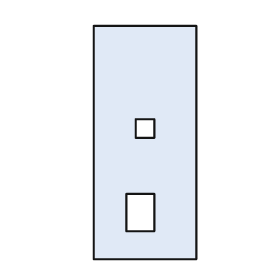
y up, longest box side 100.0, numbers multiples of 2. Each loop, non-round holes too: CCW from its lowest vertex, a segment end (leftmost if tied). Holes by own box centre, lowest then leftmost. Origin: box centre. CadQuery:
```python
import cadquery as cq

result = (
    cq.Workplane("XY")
    .moveTo(-22.0, -50.0)
    .lineTo(22.0, -50.0)
    .lineTo(22.0, 50.0)
    .lineTo(-22.0, 50.0)
    .close()
    .moveTo(-8.0, -38.0)
    .lineTo(4.0, -38.0)
    .lineTo(4.0, -22.0)
    .lineTo(-8.0, -22.0)
    .close()
    .moveTo(-4.0, 2.0)
    .lineTo(4.0, 2.0)
    .lineTo(4.0, 10.0)
    .lineTo(-4.0, 10.0)
    .close()
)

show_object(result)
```